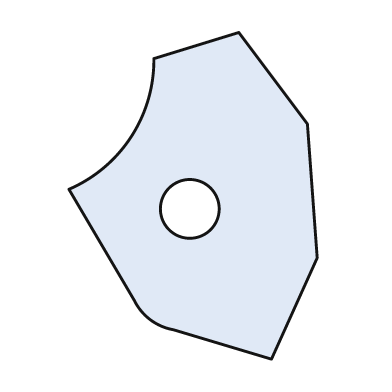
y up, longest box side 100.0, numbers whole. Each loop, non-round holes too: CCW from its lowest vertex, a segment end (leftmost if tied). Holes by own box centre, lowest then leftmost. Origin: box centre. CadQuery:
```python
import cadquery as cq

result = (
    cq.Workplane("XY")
    .moveTo(24.0, -50.0)
    .lineTo(38.0, -19.0)
    .lineTo(35.0, 22.0)
    .lineTo(14.0, 50.0)
    .lineTo(-12.0, 42.0)
    .threePointArc((-19.0, 18.0), (-38.0, 2.0))
    .lineTo(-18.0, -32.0)
    .threePointArc((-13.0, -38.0), (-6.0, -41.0))
    .close()
    .moveTo(-1.0, -4.0)
    .circle(9.0)
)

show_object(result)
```